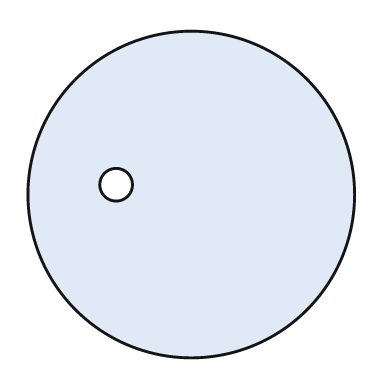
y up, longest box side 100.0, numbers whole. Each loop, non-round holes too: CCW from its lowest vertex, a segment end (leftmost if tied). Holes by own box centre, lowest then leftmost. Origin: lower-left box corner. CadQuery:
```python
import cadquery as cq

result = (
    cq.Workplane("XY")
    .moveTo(50.0, 50.0)
    .circle(50.0)
    .moveTo(27.0, 53.0)
    .circle(5.0)
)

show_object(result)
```